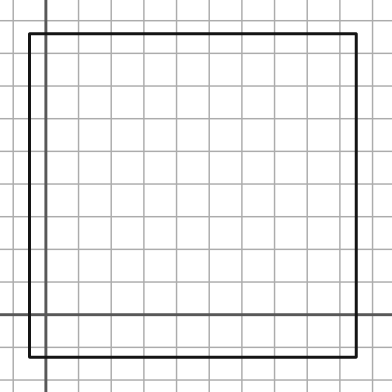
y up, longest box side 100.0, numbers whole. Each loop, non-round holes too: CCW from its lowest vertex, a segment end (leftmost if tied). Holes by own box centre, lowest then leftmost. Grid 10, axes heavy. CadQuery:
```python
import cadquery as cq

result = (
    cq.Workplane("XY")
    .moveTo(-5.0, -13.0)
    .lineTo(95.0, -13.0)
    .lineTo(95.0, 86.0)
    .lineTo(-5.0, 86.0)
    .close()
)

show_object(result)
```